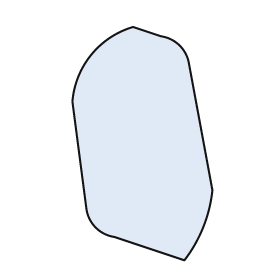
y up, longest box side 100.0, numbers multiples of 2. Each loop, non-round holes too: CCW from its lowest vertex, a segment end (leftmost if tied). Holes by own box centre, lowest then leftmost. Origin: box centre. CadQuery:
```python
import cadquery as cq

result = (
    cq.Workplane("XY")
    .moveTo(18.0, -50.0)
    .threePointArc((26.0, -36.0), (30.0, -20.0))
    .lineTo(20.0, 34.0)
    .threePointArc((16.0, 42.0), (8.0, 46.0))
    .lineTo(-4.0, 50.0)
    .threePointArc((-22.0, 38.0), (-30.0, 18.0))
    .lineTo(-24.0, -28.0)
    .threePointArc((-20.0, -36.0), (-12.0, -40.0))
    .close()
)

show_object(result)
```